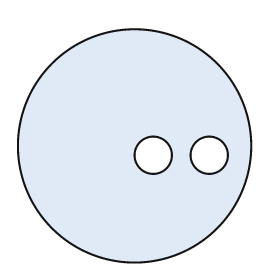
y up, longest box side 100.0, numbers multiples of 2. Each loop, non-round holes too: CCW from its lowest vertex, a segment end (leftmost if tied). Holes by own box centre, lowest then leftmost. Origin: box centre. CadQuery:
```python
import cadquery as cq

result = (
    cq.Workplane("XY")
    .moveTo(0.0, 0.0)
    .circle(50.0)
    .moveTo(8.0, -4.0)
    .circle(8.0)
    .moveTo(32.0, -4.0)
    .circle(8.0)
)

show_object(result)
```